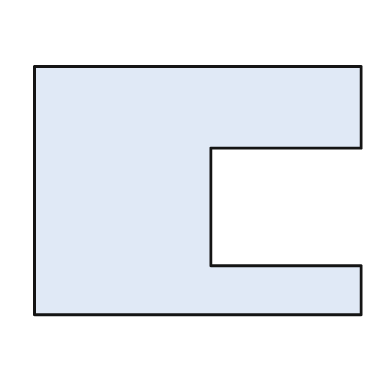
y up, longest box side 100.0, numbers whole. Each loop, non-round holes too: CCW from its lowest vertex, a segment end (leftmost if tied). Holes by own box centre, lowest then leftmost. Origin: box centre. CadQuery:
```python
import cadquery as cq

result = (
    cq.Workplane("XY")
    .moveTo(-50.0, -38.0)
    .lineTo(50.0, -38.0)
    .lineTo(50.0, -23.0)
    .lineTo(4.0, -23.0)
    .lineTo(4.0, 13.0)
    .lineTo(50.0, 13.0)
    .lineTo(50.0, 38.0)
    .lineTo(-50.0, 38.0)
    .close()
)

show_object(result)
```